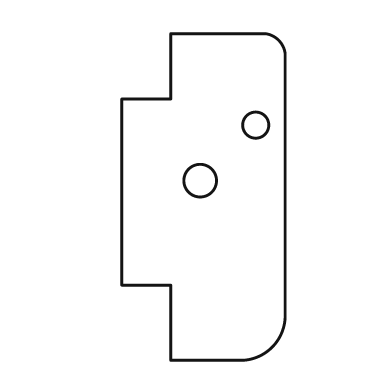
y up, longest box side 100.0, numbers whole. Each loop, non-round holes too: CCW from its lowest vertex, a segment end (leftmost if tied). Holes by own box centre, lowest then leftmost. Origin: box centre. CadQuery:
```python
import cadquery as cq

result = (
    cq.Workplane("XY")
    .moveTo(-10.0, -50.0)
    .lineTo(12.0, -50.0)
    .threePointArc((21.0, -46.0), (25.0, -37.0))
    .lineTo(25.0, 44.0)
    .threePointArc((23.0, 48.0), (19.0, 50.0))
    .lineTo(-10.0, 50.0)
    .lineTo(-10.0, 30.0)
    .lineTo(-25.0, 30.0)
    .lineTo(-25.0, -27.0)
    .lineTo(-10.0, -27.0)
    .close()
    .moveTo(-1.0, 5.0)
    .circle(5.0)
    .moveTo(16.0, 22.0)
    .circle(4.0)
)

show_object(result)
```